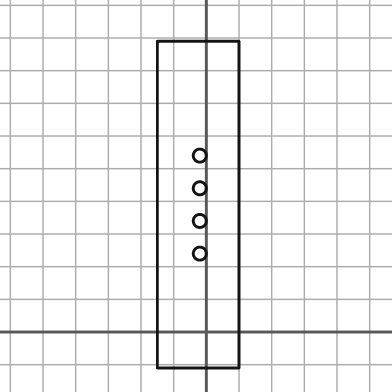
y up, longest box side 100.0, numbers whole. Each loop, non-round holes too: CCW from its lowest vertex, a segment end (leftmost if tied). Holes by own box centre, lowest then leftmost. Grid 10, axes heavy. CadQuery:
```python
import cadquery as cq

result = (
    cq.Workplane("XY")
    .moveTo(-15.0, -11.0)
    .lineTo(10.0, -11.0)
    .lineTo(10.0, 89.0)
    .lineTo(-15.0, 89.0)
    .close()
    .moveTo(-2.0, 24.0)
    .circle(2.0)
    .moveTo(-2.0, 34.0)
    .circle(2.0)
    .moveTo(-2.0, 44.0)
    .circle(2.0)
    .moveTo(-2.0, 54.0)
    .circle(2.0)
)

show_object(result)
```